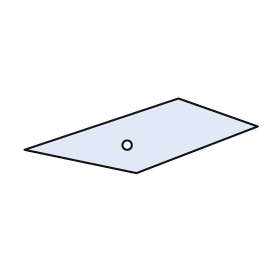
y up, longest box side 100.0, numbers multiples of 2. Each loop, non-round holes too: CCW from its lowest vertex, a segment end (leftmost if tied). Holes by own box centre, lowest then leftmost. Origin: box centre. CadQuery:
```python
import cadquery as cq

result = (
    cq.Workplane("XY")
    .moveTo(-2.0, -16.0)
    .lineTo(50.0, 4.0)
    .lineTo(16.0, 16.0)
    .lineTo(-50.0, -6.0)
    .close()
    .moveTo(-6.0, -4.0)
    .circle(2.0)
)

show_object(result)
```